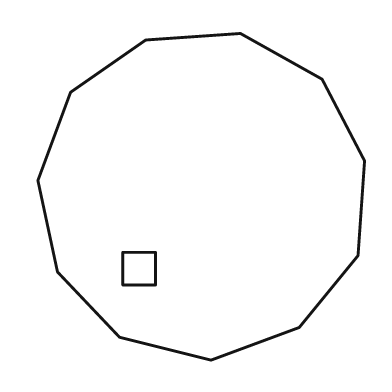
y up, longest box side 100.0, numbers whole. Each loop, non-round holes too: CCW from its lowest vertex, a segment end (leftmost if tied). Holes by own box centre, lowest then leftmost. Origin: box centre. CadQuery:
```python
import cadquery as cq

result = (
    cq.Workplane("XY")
    .moveTo(3.0, -50.0)
    .lineTo(30.0, -40.0)
    .lineTo(48.0, -18.0)
    .lineTo(50.0, 11.0)
    .lineTo(37.0, 36.0)
    .lineTo(12.0, 50.0)
    .lineTo(-17.0, 48.0)
    .lineTo(-40.0, 32.0)
    .lineTo(-50.0, 5.0)
    .lineTo(-44.0, -23.0)
    .lineTo(-25.0, -43.0)
    .close()
    .moveTo(-24.0, -27.0)
    .lineTo(-14.0, -27.0)
    .lineTo(-14.0, -17.0)
    .lineTo(-24.0, -17.0)
    .close()
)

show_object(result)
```